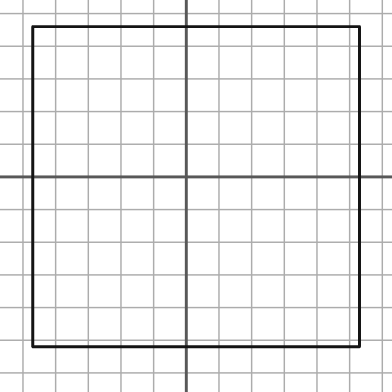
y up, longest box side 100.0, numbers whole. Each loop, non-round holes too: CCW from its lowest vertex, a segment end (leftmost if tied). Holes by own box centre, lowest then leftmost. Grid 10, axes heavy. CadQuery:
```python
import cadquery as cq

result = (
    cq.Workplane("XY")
    .moveTo(-47.0, -52.0)
    .lineTo(53.0, -52.0)
    .lineTo(53.0, 46.0)
    .lineTo(-47.0, 46.0)
    .close()
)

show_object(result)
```